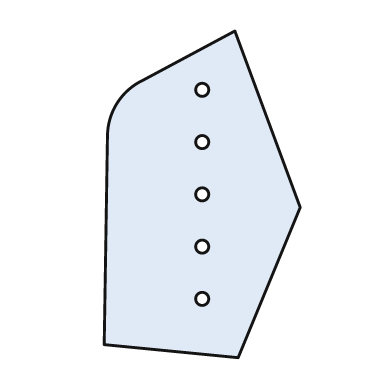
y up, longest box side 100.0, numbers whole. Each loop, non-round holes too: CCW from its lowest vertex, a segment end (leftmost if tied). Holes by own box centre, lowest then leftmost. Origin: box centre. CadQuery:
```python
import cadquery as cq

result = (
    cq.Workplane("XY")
    .moveTo(11.0, -50.0)
    .lineTo(30.0, -4.0)
    .lineTo(10.0, 50.0)
    .lineTo(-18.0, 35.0)
    .threePointArc((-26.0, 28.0), (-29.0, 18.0))
    .lineTo(-30.0, -46.0)
    .close()
    .moveTo(0.0, -32.0)
    .circle(2.0)
    .moveTo(0.0, -16.0)
    .circle(2.0)
    .moveTo(0.0, 0.0)
    .circle(2.0)
    .moveTo(0.0, 16.0)
    .circle(2.0)
    .moveTo(0.0, 32.0)
    .circle(2.0)
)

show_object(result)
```